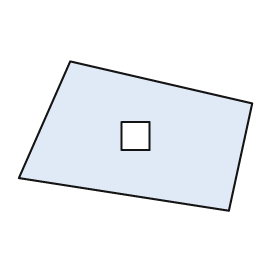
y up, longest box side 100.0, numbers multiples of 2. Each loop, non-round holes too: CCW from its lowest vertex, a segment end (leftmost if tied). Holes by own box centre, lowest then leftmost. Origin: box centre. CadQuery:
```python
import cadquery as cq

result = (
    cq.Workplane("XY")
    .moveTo(40.0, -32.0)
    .lineTo(50.0, 14.0)
    .lineTo(-28.0, 32.0)
    .lineTo(-50.0, -18.0)
    .close()
    .moveTo(-6.0, -6.0)
    .lineTo(6.0, -6.0)
    .lineTo(6.0, 6.0)
    .lineTo(-6.0, 6.0)
    .close()
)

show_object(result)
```